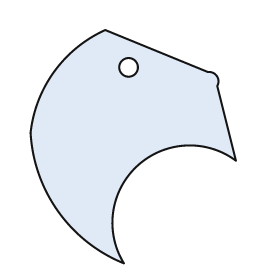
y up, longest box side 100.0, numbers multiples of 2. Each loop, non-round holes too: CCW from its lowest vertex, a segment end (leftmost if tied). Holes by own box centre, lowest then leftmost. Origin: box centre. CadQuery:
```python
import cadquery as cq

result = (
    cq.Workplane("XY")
    .moveTo(-4.0, -50.0)
    .threePointArc((2.0, -8.0), (44.0, -6.0))
    .lineTo(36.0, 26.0)
    .threePointArc((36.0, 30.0), (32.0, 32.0))
    .lineTo(-12.0, 50.0)
    .threePointArc((-34.0, 32.0), (-44.0, 6.0))
    .threePointArc((-32.0, -28.0), (-4.0, -50.0))
    .close()
    .moveTo(-2.0, 34.0)
    .circle(4.0)
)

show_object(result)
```